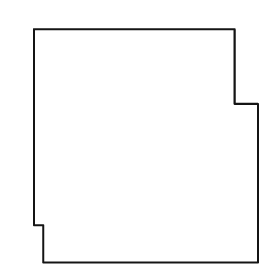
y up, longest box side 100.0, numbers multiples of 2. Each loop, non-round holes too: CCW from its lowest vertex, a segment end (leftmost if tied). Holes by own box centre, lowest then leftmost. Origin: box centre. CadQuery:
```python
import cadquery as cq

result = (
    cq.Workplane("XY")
    .moveTo(-44.0, -50.0)
    .lineTo(48.0, -50.0)
    .lineTo(48.0, 18.0)
    .lineTo(38.0, 18.0)
    .lineTo(38.0, 50.0)
    .lineTo(-48.0, 50.0)
    .lineTo(-48.0, -34.0)
    .lineTo(-44.0, -34.0)
    .close()
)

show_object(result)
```